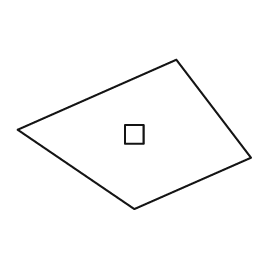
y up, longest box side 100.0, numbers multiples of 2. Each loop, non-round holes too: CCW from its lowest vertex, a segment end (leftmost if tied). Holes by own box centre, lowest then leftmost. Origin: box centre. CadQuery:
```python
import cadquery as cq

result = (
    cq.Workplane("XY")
    .moveTo(0.0, -32.0)
    .lineTo(50.0, -10.0)
    .lineTo(18.0, 32.0)
    .lineTo(-50.0, 2.0)
    .close()
    .moveTo(-4.0, -4.0)
    .lineTo(4.0, -4.0)
    .lineTo(4.0, 4.0)
    .lineTo(-4.0, 4.0)
    .close()
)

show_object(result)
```